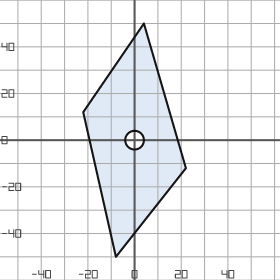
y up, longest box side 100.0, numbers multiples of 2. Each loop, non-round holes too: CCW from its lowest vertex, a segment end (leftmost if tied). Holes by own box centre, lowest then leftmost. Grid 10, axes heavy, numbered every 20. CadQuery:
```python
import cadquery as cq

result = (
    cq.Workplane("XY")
    .moveTo(-8.0, -50.0)
    .lineTo(22.0, -12.0)
    .lineTo(4.0, 50.0)
    .lineTo(-22.0, 12.0)
    .close()
    .moveTo(0.0, 0.0)
    .circle(4.0)
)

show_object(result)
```